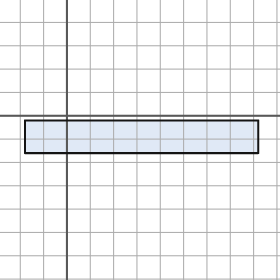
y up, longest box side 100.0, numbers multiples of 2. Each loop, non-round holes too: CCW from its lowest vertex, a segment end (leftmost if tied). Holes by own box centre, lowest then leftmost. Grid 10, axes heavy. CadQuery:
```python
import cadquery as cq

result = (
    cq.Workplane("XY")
    .moveTo(-18.0, -16.0)
    .lineTo(82.0, -16.0)
    .lineTo(82.0, -2.0)
    .lineTo(-18.0, -2.0)
    .close()
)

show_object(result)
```